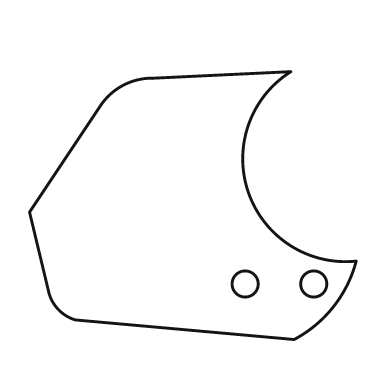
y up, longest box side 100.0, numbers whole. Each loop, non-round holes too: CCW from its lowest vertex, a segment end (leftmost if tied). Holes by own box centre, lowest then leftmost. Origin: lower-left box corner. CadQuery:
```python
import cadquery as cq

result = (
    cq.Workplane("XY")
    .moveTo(81.0, 0.0)
    .threePointArc((93.0, 10.0), (100.0, 24.0))
    .threePointArc((67.0, 45.0), (80.0, 82.0))
    .lineTo(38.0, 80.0)
    .threePointArc((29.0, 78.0), (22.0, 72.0))
    .lineTo(0.0, 39.0)
    .lineTo(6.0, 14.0)
    .threePointArc((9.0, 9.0), (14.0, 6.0))
    .close()
    .moveTo(66.0, 17.0)
    .circle(4.0)
    .moveTo(87.0, 17.0)
    .circle(4.0)
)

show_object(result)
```